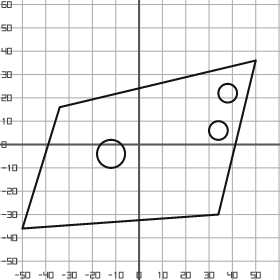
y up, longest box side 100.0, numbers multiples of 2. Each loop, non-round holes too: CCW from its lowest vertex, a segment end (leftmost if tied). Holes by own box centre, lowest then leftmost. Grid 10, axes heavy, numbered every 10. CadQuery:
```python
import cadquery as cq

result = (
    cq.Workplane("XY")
    .moveTo(-50.0, -36.0)
    .lineTo(34.0, -30.0)
    .lineTo(50.0, 36.0)
    .lineTo(-34.0, 16.0)
    .close()
    .moveTo(-12.0, -4.0)
    .circle(6.0)
    .moveTo(34.0, 6.0)
    .circle(4.0)
    .moveTo(38.0, 22.0)
    .circle(4.0)
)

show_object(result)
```